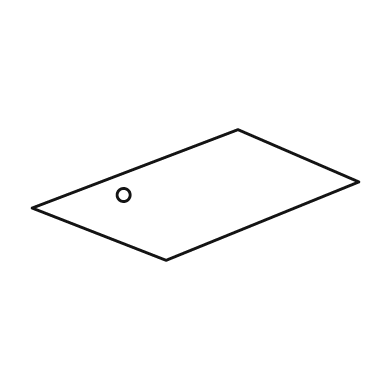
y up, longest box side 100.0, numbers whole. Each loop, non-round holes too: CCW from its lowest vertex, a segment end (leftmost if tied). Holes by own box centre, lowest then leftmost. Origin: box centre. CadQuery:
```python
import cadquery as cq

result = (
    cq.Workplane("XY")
    .moveTo(-9.0, -20.0)
    .lineTo(50.0, 4.0)
    .lineTo(13.0, 20.0)
    .lineTo(-50.0, -4.0)
    .close()
    .moveTo(-22.0, 0.0)
    .circle(2.0)
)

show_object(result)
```